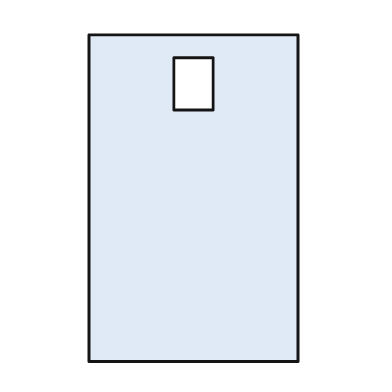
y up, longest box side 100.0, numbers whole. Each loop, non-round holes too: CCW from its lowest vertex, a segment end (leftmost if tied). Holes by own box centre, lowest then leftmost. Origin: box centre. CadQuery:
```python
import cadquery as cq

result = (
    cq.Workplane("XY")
    .moveTo(-32.0, -50.0)
    .lineTo(32.0, -50.0)
    .lineTo(32.0, 50.0)
    .lineTo(-32.0, 50.0)
    .close()
    .moveTo(-6.0, 27.0)
    .lineTo(6.0, 27.0)
    .lineTo(6.0, 43.0)
    .lineTo(-6.0, 43.0)
    .close()
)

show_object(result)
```